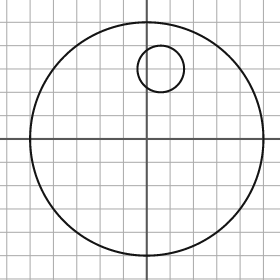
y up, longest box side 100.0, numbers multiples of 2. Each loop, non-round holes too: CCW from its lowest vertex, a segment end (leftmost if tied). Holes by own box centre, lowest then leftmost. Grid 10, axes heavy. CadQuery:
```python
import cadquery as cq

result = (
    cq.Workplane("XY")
    .moveTo(0.0, 0.0)
    .circle(50.0)
    .moveTo(6.0, 30.0)
    .circle(10.0)
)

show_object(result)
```